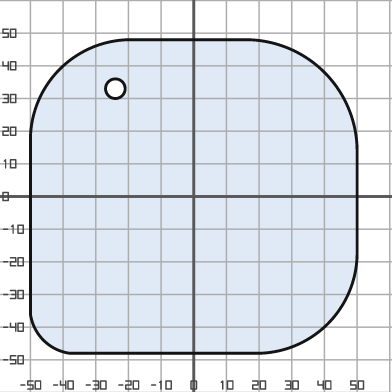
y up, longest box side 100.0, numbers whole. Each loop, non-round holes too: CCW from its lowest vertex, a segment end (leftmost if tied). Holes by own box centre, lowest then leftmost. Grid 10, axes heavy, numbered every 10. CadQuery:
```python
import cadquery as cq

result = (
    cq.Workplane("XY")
    .moveTo(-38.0, -48.0)
    .lineTo(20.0, -48.0)
    .threePointArc((41.0, -39.0), (50.0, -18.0))
    .lineTo(50.0, 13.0)
    .threePointArc((40.0, 38.0), (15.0, 48.0))
    .lineTo(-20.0, 48.0)
    .threePointArc((-41.0, 39.0), (-50.0, 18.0))
    .lineTo(-50.0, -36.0)
    .threePointArc((-46.0, -44.0), (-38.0, -48.0))
    .close()
    .moveTo(-24.0, 33.0)
    .circle(3.0)
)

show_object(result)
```